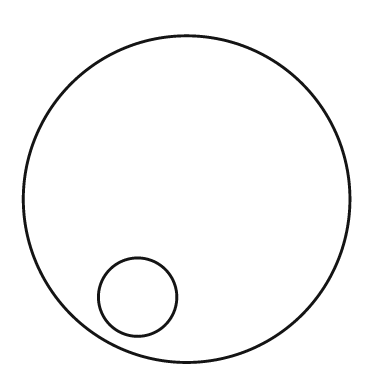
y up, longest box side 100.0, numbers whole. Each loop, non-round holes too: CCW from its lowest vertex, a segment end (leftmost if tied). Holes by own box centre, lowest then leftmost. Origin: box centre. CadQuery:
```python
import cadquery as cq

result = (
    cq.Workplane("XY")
    .moveTo(0.0, 0.0)
    .circle(50.0)
    .moveTo(-15.0, -30.0)
    .circle(12.0)
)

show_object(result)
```